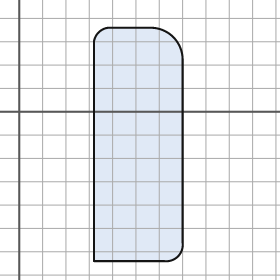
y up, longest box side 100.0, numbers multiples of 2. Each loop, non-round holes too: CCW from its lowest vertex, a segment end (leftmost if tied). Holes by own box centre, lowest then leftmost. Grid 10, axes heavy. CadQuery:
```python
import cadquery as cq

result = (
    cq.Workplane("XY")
    .moveTo(32.0, -64.0)
    .lineTo(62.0, -64.0)
    .threePointArc((68.0, -62.0), (70.0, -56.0))
    .lineTo(70.0, 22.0)
    .threePointArc((66.0, 32.0), (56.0, 36.0))
    .lineTo(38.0, 36.0)
    .threePointArc((34.0, 34.0), (32.0, 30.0))
    .close()
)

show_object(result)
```